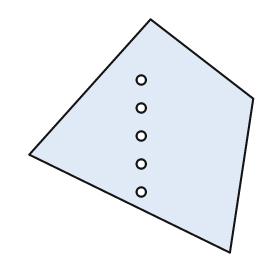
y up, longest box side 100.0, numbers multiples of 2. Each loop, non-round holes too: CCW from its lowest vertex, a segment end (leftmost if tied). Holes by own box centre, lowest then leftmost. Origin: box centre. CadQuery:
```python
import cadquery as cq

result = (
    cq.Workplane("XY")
    .moveTo(38.0, -50.0)
    .lineTo(48.0, 16.0)
    .lineTo(4.0, 50.0)
    .lineTo(-48.0, -8.0)
    .close()
    .moveTo(0.0, -24.0)
    .circle(2.0)
    .moveTo(0.0, -12.0)
    .circle(2.0)
    .moveTo(0.0, 0.0)
    .circle(2.0)
    .moveTo(0.0, 12.0)
    .circle(2.0)
    .moveTo(0.0, 24.0)
    .circle(2.0)
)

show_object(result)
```